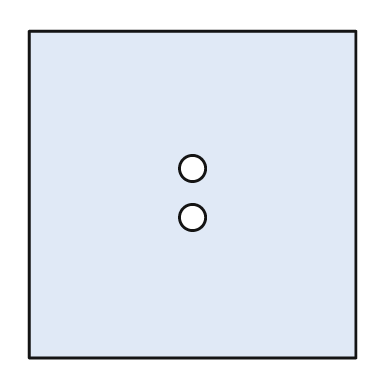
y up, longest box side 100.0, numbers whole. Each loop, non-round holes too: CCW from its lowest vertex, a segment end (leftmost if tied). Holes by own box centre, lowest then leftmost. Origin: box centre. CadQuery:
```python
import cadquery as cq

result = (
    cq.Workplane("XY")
    .moveTo(-50.0, -50.0)
    .lineTo(50.0, -50.0)
    .lineTo(50.0, 50.0)
    .lineTo(-50.0, 50.0)
    .close()
    .moveTo(0.0, -7.0)
    .circle(4.0)
    .moveTo(0.0, 8.0)
    .circle(4.0)
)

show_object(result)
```